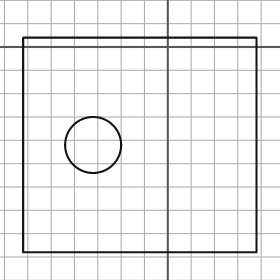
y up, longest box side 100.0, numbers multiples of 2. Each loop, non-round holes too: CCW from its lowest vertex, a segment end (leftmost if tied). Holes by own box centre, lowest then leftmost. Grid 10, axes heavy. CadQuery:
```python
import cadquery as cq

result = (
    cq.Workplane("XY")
    .moveTo(-62.0, -88.0)
    .lineTo(38.0, -88.0)
    .lineTo(38.0, 4.0)
    .lineTo(-62.0, 4.0)
    .close()
    .moveTo(-32.0, -42.0)
    .circle(12.0)
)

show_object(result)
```